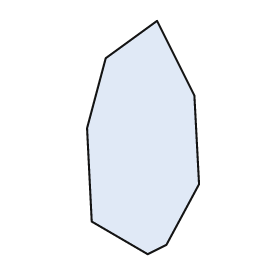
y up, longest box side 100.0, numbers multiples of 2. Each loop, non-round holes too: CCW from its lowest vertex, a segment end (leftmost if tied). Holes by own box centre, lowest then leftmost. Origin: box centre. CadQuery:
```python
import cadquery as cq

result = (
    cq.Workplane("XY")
    .moveTo(2.0, -50.0)
    .lineTo(10.0, -46.0)
    .lineTo(24.0, -20.0)
    .lineTo(22.0, 18.0)
    .lineTo(6.0, 50.0)
    .lineTo(-16.0, 34.0)
    .lineTo(-24.0, 4.0)
    .lineTo(-22.0, -36.0)
    .close()
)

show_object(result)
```